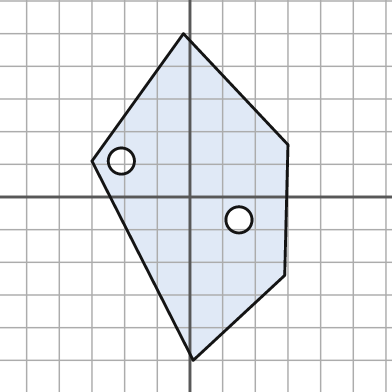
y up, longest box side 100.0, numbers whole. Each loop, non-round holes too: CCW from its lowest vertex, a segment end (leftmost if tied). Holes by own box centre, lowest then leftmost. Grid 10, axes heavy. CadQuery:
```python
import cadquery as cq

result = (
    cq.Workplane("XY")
    .moveTo(1.0, -50.0)
    .lineTo(29.0, -24.0)
    .lineTo(30.0, 16.0)
    .lineTo(-2.0, 50.0)
    .lineTo(-30.0, 11.0)
    .close()
    .moveTo(15.0, -7.0)
    .circle(4.0)
    .moveTo(-21.0, 11.0)
    .circle(4.0)
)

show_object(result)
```